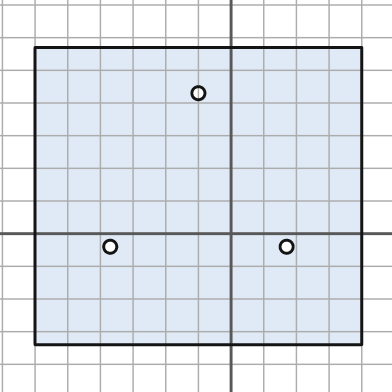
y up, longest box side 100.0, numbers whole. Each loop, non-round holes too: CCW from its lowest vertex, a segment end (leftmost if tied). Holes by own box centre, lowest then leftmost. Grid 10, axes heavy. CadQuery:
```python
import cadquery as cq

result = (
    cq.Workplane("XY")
    .moveTo(-60.0, -34.0)
    .lineTo(40.0, -34.0)
    .lineTo(40.0, 57.0)
    .lineTo(-60.0, 57.0)
    .close()
    .moveTo(-37.0, -4.0)
    .circle(2.0)
    .moveTo(17.0, -4.0)
    .circle(2.0)
    .moveTo(-10.0, 43.0)
    .circle(2.0)
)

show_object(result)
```